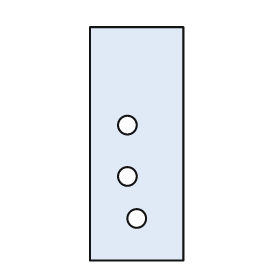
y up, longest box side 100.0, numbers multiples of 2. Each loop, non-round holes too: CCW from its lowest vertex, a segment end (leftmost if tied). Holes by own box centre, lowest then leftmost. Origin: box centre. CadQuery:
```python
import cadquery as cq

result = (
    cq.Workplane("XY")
    .moveTo(-20.0, -50.0)
    .lineTo(20.0, -50.0)
    .lineTo(20.0, 50.0)
    .lineTo(-20.0, 50.0)
    .close()
    .moveTo(0.0, -32.0)
    .circle(4.0)
    .moveTo(-4.0, -14.0)
    .circle(4.0)
    .moveTo(-4.0, 8.0)
    .circle(4.0)
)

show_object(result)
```